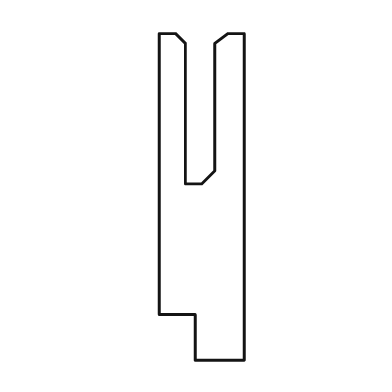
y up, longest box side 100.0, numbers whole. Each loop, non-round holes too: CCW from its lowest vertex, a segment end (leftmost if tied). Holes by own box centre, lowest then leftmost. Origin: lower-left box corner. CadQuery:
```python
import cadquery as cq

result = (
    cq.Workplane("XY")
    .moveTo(11.0, 0.0)
    .lineTo(26.0, 0.0)
    .lineTo(26.0, 100.0)
    .lineTo(21.0, 100.0)
    .lineTo(17.0, 97.0)
    .lineTo(17.0, 58.0)
    .lineTo(13.0, 54.0)
    .lineTo(8.0, 54.0)
    .lineTo(8.0, 97.0)
    .lineTo(5.0, 100.0)
    .lineTo(0.0, 100.0)
    .lineTo(0.0, 14.0)
    .lineTo(11.0, 14.0)
    .close()
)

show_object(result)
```